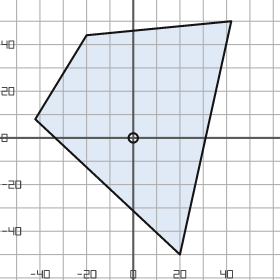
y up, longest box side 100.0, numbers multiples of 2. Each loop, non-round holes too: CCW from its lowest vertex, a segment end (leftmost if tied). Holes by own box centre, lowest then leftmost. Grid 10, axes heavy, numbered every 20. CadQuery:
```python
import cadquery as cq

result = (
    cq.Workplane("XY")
    .moveTo(20.0, -50.0)
    .lineTo(42.0, 50.0)
    .lineTo(-20.0, 44.0)
    .lineTo(-42.0, 8.0)
    .close()
    .moveTo(0.0, 0.0)
    .circle(2.0)
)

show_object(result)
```